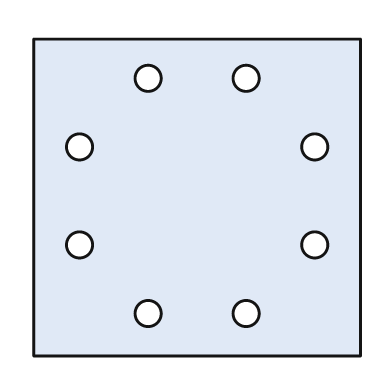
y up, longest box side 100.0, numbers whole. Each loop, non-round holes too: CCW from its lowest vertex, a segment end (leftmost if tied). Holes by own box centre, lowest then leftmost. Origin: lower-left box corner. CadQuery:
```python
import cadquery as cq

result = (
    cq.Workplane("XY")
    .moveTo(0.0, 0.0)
    .lineTo(100.0, 0.0)
    .lineTo(100.0, 97.0)
    .lineTo(0.0, 97.0)
    .close()
    .moveTo(35.0, 13.0)
    .circle(4.0)
    .moveTo(65.0, 13.0)
    .circle(4.0)
    .moveTo(14.0, 34.0)
    .circle(4.0)
    .moveTo(86.0, 34.0)
    .circle(4.0)
    .moveTo(14.0, 64.0)
    .circle(4.0)
    .moveTo(86.0, 64.0)
    .circle(4.0)
    .moveTo(35.0, 85.0)
    .circle(4.0)
    .moveTo(65.0, 85.0)
    .circle(4.0)
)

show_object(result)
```